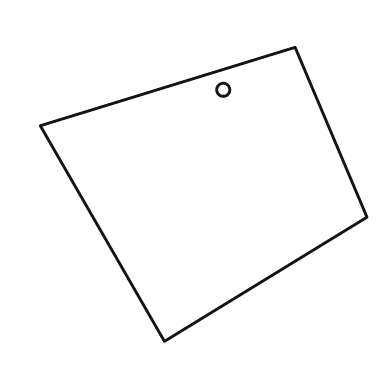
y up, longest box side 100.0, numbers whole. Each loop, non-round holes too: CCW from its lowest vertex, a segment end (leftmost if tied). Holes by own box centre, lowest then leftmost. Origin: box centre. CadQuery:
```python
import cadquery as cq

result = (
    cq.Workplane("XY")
    .moveTo(-12.0, -45.0)
    .lineTo(50.0, -7.0)
    .lineTo(28.0, 45.0)
    .lineTo(-50.0, 21.0)
    .close()
    .moveTo(6.0, 32.0)
    .circle(2.0)
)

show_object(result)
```